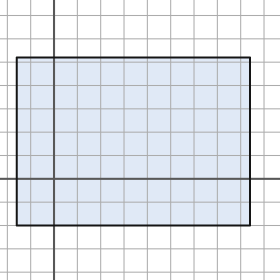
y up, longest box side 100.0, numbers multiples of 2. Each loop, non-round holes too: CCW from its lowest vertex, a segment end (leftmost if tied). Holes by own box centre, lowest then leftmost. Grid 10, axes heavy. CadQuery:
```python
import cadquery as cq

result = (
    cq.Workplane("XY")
    .moveTo(-16.0, -20.0)
    .lineTo(84.0, -20.0)
    .lineTo(84.0, 52.0)
    .lineTo(-16.0, 52.0)
    .close()
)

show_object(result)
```